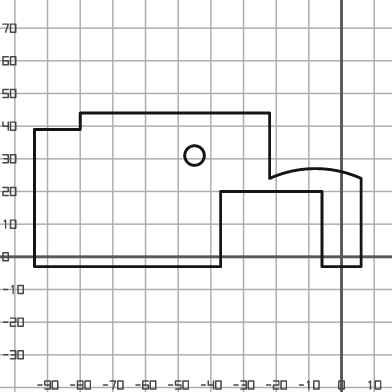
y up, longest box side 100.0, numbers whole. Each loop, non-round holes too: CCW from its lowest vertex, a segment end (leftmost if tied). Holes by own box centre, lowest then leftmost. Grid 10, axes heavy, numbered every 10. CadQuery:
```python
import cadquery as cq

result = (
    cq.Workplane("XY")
    .moveTo(-94.0, -3.0)
    .lineTo(-37.0, -3.0)
    .lineTo(-37.0, 20.0)
    .lineTo(-6.0, 20.0)
    .lineTo(-6.0, -3.0)
    .lineTo(6.0, -3.0)
    .lineTo(6.0, 24.0)
    .threePointArc((-8.0, 27.0), (-22.0, 24.0))
    .lineTo(-22.0, 44.0)
    .lineTo(-80.0, 44.0)
    .lineTo(-80.0, 39.0)
    .lineTo(-94.0, 39.0)
    .close()
    .moveTo(-45.0, 31.0)
    .circle(3.0)
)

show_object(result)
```